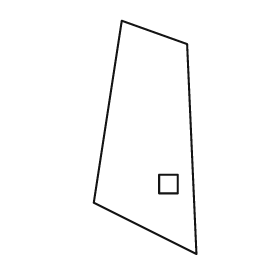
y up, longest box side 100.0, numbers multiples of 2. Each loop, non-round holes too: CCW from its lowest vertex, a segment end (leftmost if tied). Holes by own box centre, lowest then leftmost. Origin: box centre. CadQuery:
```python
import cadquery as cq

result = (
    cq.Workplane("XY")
    .moveTo(22.0, -50.0)
    .lineTo(18.0, 40.0)
    .lineTo(-10.0, 50.0)
    .lineTo(-22.0, -28.0)
    .close()
    .moveTo(6.0, -24.0)
    .lineTo(14.0, -24.0)
    .lineTo(14.0, -16.0)
    .lineTo(6.0, -16.0)
    .close()
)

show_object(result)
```